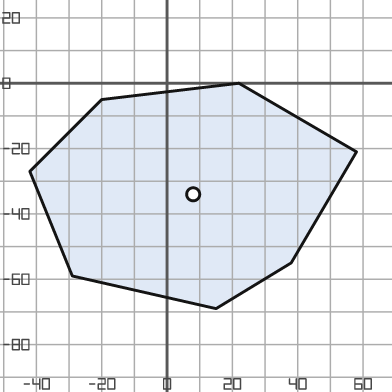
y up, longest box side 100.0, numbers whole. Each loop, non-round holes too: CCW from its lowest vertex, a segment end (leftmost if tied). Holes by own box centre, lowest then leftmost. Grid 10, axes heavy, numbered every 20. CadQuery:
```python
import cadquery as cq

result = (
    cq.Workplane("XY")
    .moveTo(15.0, -69.0)
    .lineTo(38.0, -55.0)
    .lineTo(58.0, -21.0)
    .lineTo(22.0, 0.0)
    .lineTo(-20.0, -5.0)
    .lineTo(-42.0, -27.0)
    .lineTo(-29.0, -59.0)
    .close()
    .moveTo(8.0, -34.0)
    .circle(2.0)
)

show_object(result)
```